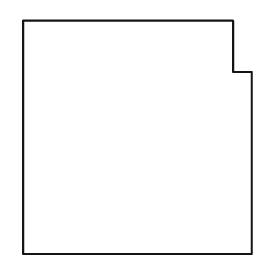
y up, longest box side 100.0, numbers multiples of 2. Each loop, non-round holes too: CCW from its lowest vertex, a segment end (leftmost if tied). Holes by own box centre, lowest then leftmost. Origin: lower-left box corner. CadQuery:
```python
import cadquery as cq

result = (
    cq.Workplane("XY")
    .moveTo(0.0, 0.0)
    .lineTo(98.0, 0.0)
    .lineTo(98.0, 78.0)
    .lineTo(90.0, 78.0)
    .lineTo(90.0, 100.0)
    .lineTo(0.0, 100.0)
    .close()
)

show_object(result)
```